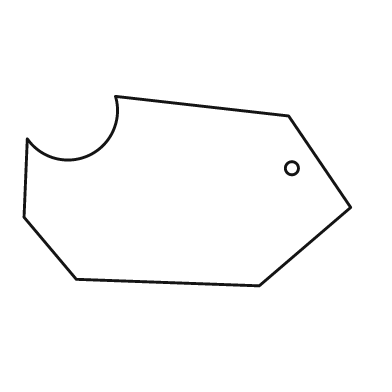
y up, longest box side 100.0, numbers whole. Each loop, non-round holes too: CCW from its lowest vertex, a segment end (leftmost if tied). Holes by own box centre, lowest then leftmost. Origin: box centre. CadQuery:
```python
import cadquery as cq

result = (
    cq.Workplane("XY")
    .moveTo(22.0, -29.0)
    .lineTo(50.0, -5.0)
    .lineTo(31.0, 23.0)
    .lineTo(-22.0, 29.0)
    .threePointArc((-30.0, 11.0), (-49.0, 16.0))
    .lineTo(-50.0, -8.0)
    .lineTo(-34.0, -27.0)
    .close()
    .moveTo(32.0, 7.0)
    .circle(2.0)
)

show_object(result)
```